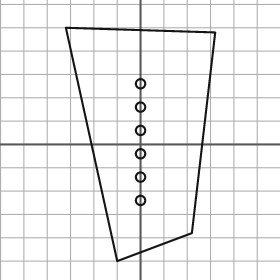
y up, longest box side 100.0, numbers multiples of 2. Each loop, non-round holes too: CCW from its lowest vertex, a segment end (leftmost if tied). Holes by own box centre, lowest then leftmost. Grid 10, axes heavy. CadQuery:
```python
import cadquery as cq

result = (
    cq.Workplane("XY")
    .moveTo(-10.0, -50.0)
    .lineTo(22.0, -38.0)
    .lineTo(32.0, 48.0)
    .lineTo(-32.0, 50.0)
    .close()
    .moveTo(0.0, -24.0)
    .circle(2.0)
    .moveTo(0.0, -14.0)
    .circle(2.0)
    .moveTo(0.0, -4.0)
    .circle(2.0)
    .moveTo(0.0, 6.0)
    .circle(2.0)
    .moveTo(0.0, 16.0)
    .circle(2.0)
    .moveTo(0.0, 26.0)
    .circle(2.0)
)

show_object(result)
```